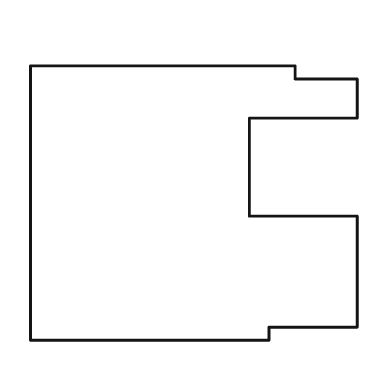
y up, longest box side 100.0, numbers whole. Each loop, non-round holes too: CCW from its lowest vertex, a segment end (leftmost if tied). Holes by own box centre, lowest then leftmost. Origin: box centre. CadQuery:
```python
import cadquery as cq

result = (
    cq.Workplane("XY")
    .moveTo(-50.0, -42.0)
    .lineTo(23.0, -42.0)
    .lineTo(23.0, -38.0)
    .lineTo(50.0, -38.0)
    .lineTo(50.0, -4.0)
    .lineTo(17.0, -4.0)
    .lineTo(17.0, 26.0)
    .lineTo(50.0, 26.0)
    .lineTo(50.0, 38.0)
    .lineTo(31.0, 38.0)
    .lineTo(31.0, 42.0)
    .lineTo(-50.0, 42.0)
    .close()
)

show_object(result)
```